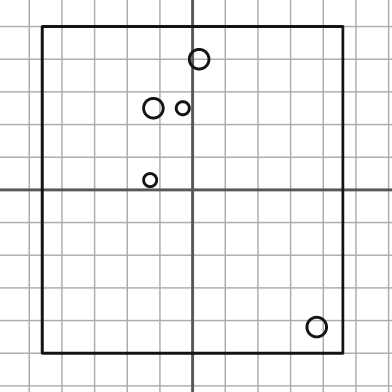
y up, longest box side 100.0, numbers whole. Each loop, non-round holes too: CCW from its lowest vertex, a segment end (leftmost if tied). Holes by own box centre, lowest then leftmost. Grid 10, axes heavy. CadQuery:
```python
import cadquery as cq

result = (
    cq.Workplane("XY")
    .moveTo(-46.0, -50.0)
    .lineTo(46.0, -50.0)
    .lineTo(46.0, 50.0)
    .lineTo(-46.0, 50.0)
    .close()
    .moveTo(38.0, -42.0)
    .circle(3.0)
    .moveTo(-13.0, 3.0)
    .circle(2.0)
    .moveTo(-12.0, 25.0)
    .circle(3.0)
    .moveTo(-3.0, 25.0)
    .circle(2.0)
    .moveTo(2.0, 40.0)
    .circle(3.0)
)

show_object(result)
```